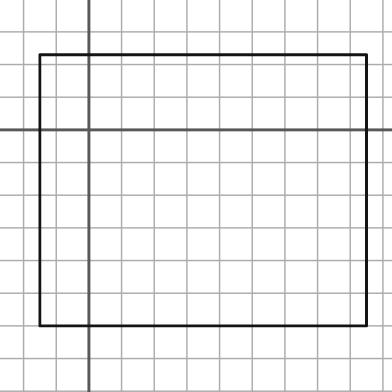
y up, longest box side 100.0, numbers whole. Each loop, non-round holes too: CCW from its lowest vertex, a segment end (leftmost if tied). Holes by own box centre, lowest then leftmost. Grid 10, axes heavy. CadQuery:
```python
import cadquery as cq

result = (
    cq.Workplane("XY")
    .moveTo(-15.0, -60.0)
    .lineTo(85.0, -60.0)
    .lineTo(85.0, 23.0)
    .lineTo(-15.0, 23.0)
    .close()
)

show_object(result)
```